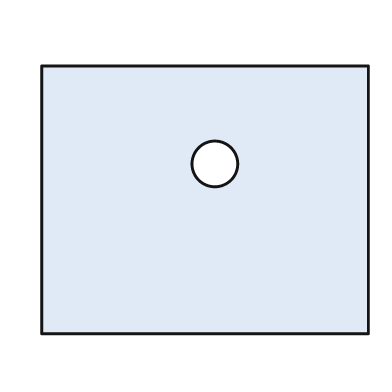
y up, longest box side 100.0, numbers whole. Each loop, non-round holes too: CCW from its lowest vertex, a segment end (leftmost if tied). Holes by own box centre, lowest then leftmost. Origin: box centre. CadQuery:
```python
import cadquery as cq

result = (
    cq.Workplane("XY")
    .moveTo(-50.0, -41.0)
    .lineTo(50.0, -41.0)
    .lineTo(50.0, 41.0)
    .lineTo(-50.0, 41.0)
    .close()
    .moveTo(3.0, 11.0)
    .circle(7.0)
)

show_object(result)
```